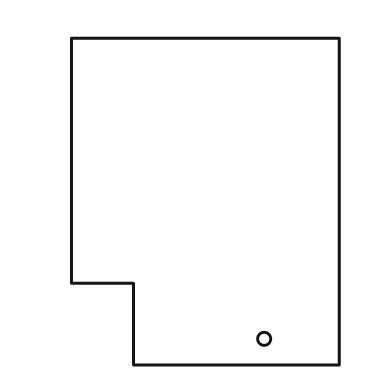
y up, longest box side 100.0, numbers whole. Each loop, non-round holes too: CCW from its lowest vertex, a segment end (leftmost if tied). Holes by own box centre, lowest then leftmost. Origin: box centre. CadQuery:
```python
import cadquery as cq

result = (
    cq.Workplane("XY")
    .moveTo(-22.0, -50.0)
    .lineTo(41.0, -50.0)
    .lineTo(41.0, 50.0)
    .lineTo(-41.0, 50.0)
    .lineTo(-41.0, -25.0)
    .lineTo(-22.0, -25.0)
    .close()
    .moveTo(18.0, -42.0)
    .circle(2.0)
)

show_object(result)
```